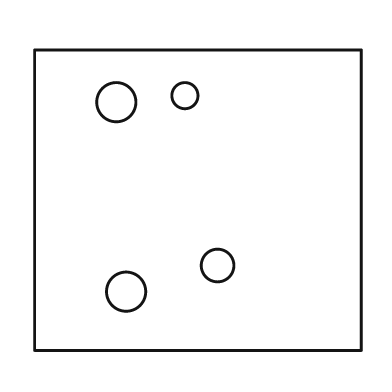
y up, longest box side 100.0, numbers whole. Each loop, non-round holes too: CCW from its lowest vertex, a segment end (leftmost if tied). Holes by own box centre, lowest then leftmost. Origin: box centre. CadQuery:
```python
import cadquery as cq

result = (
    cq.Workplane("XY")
    .moveTo(-50.0, -46.0)
    .lineTo(50.0, -46.0)
    .lineTo(50.0, 46.0)
    .lineTo(-50.0, 46.0)
    .close()
    .moveTo(-22.0, -28.0)
    .circle(6.0)
    .moveTo(6.0, -20.0)
    .circle(5.0)
    .moveTo(-25.0, 30.0)
    .circle(6.0)
    .moveTo(-4.0, 32.0)
    .circle(4.0)
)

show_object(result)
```